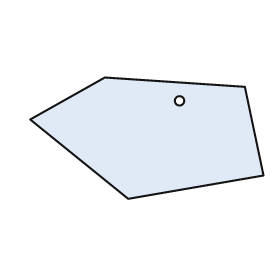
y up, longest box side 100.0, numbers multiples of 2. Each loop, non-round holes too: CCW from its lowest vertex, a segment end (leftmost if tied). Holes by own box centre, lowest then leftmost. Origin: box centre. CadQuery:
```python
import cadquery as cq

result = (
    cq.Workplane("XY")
    .moveTo(-8.0, -26.0)
    .lineTo(50.0, -16.0)
    .lineTo(42.0, 22.0)
    .lineTo(-18.0, 26.0)
    .lineTo(-50.0, 8.0)
    .close()
    .moveTo(14.0, 16.0)
    .circle(2.0)
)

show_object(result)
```